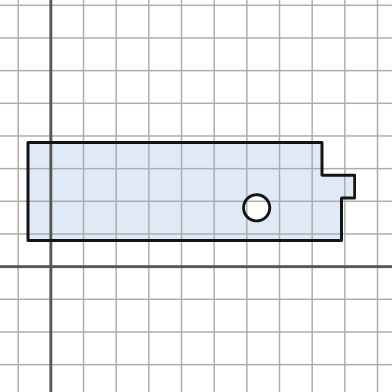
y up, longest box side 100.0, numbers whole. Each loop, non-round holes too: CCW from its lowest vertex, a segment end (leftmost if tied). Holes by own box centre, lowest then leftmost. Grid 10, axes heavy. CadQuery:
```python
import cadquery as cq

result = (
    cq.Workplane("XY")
    .moveTo(-7.0, 8.0)
    .lineTo(89.0, 8.0)
    .lineTo(89.0, 21.0)
    .lineTo(93.0, 21.0)
    .lineTo(93.0, 28.0)
    .lineTo(83.0, 28.0)
    .lineTo(83.0, 38.0)
    .lineTo(-7.0, 38.0)
    .close()
    .moveTo(63.0, 18.0)
    .circle(4.0)
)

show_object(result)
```